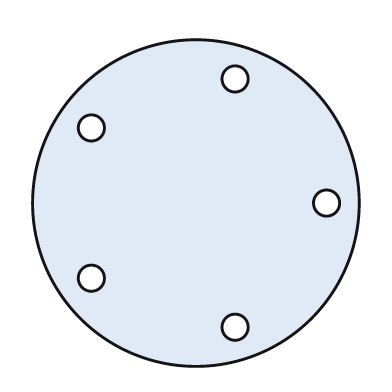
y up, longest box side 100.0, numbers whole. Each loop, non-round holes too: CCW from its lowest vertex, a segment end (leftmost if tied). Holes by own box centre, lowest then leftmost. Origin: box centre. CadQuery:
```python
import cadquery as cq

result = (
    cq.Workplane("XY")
    .moveTo(0.0, 0.0)
    .circle(50.0)
    .moveTo(12.0, -38.0)
    .circle(4.0)
    .moveTo(-32.0, -23.0)
    .circle(4.0)
    .moveTo(40.0, 0.0)
    .circle(4.0)
    .moveTo(-32.0, 23.0)
    .circle(4.0)
    .moveTo(12.0, 38.0)
    .circle(4.0)
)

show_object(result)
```